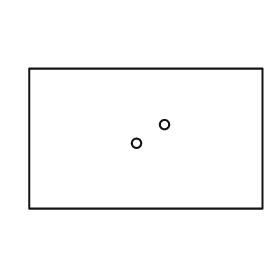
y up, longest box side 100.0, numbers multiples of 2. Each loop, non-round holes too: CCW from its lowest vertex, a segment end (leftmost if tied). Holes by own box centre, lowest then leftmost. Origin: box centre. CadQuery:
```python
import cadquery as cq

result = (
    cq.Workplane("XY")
    .moveTo(-50.0, -30.0)
    .lineTo(50.0, -30.0)
    .lineTo(50.0, 30.0)
    .lineTo(-50.0, 30.0)
    .close()
    .moveTo(-4.0, -2.0)
    .circle(2.0)
    .moveTo(8.0, 6.0)
    .circle(2.0)
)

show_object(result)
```